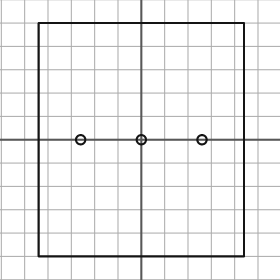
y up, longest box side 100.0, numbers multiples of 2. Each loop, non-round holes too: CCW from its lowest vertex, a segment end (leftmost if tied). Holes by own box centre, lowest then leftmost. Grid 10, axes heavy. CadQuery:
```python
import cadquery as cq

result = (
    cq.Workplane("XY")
    .moveTo(-44.0, -50.0)
    .lineTo(44.0, -50.0)
    .lineTo(44.0, 50.0)
    .lineTo(-44.0, 50.0)
    .close()
    .moveTo(-26.0, 0.0)
    .circle(2.0)
    .moveTo(0.0, 0.0)
    .circle(2.0)
    .moveTo(26.0, 0.0)
    .circle(2.0)
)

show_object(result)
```